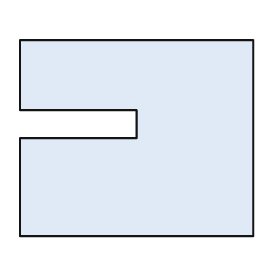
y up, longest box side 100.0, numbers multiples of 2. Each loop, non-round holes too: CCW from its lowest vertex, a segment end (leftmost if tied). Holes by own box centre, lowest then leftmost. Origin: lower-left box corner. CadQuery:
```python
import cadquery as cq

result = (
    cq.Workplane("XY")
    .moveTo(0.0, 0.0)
    .lineTo(100.0, 0.0)
    .lineTo(100.0, 84.0)
    .lineTo(0.0, 84.0)
    .lineTo(0.0, 54.0)
    .lineTo(50.0, 54.0)
    .lineTo(50.0, 42.0)
    .lineTo(0.0, 42.0)
    .close()
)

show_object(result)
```